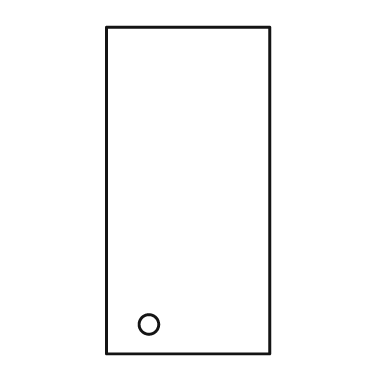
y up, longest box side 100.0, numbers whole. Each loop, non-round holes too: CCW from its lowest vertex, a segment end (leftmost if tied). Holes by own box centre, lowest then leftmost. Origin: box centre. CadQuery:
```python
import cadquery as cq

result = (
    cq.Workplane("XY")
    .moveTo(-25.0, -50.0)
    .lineTo(25.0, -50.0)
    .lineTo(25.0, 50.0)
    .lineTo(-25.0, 50.0)
    .close()
    .moveTo(-12.0, -41.0)
    .circle(3.0)
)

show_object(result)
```